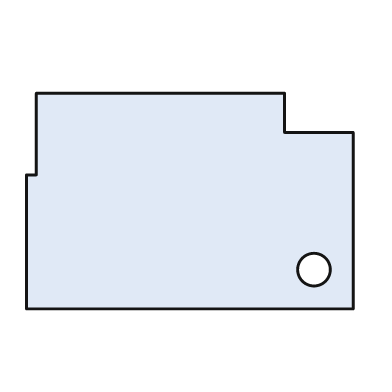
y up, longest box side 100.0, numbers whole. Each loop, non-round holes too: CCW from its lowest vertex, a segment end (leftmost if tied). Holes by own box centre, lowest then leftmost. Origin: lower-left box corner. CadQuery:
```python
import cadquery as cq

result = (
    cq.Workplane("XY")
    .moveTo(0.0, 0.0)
    .lineTo(100.0, 0.0)
    .lineTo(100.0, 54.0)
    .lineTo(79.0, 54.0)
    .lineTo(79.0, 66.0)
    .lineTo(3.0, 66.0)
    .lineTo(3.0, 41.0)
    .lineTo(0.0, 41.0)
    .close()
    .moveTo(88.0, 12.0)
    .circle(5.0)
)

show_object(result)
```